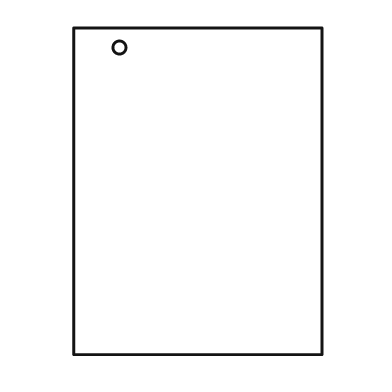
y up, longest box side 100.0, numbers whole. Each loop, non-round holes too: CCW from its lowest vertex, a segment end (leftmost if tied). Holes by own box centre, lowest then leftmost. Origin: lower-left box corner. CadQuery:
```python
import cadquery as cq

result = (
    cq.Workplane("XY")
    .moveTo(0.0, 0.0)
    .lineTo(76.0, 0.0)
    .lineTo(76.0, 100.0)
    .lineTo(0.0, 100.0)
    .close()
    .moveTo(14.0, 94.0)
    .circle(2.0)
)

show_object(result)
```